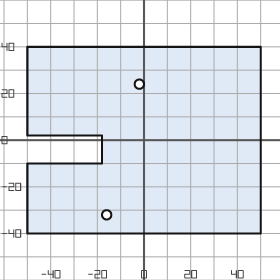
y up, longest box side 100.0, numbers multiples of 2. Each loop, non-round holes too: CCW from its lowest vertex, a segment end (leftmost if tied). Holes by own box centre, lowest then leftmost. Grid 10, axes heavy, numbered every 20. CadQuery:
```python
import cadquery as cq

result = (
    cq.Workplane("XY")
    .moveTo(-50.0, -40.0)
    .lineTo(50.0, -40.0)
    .lineTo(50.0, 40.0)
    .lineTo(-50.0, 40.0)
    .lineTo(-50.0, 2.0)
    .lineTo(-18.0, 2.0)
    .lineTo(-18.0, -10.0)
    .lineTo(-50.0, -10.0)
    .close()
    .moveTo(-16.0, -32.0)
    .circle(2.0)
    .moveTo(-2.0, 24.0)
    .circle(2.0)
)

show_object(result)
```